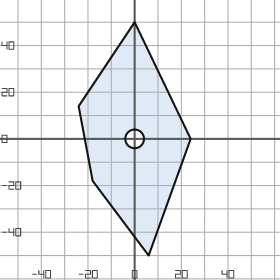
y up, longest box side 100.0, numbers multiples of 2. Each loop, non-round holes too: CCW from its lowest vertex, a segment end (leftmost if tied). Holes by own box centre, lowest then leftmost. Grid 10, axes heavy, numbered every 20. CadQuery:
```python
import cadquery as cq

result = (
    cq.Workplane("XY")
    .moveTo(6.0, -50.0)
    .lineTo(24.0, 0.0)
    .lineTo(0.0, 50.0)
    .lineTo(-24.0, 14.0)
    .lineTo(-18.0, -18.0)
    .close()
    .moveTo(0.0, 0.0)
    .circle(4.0)
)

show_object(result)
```